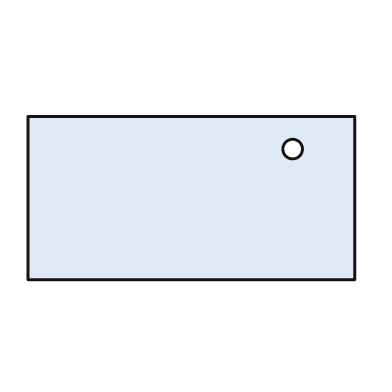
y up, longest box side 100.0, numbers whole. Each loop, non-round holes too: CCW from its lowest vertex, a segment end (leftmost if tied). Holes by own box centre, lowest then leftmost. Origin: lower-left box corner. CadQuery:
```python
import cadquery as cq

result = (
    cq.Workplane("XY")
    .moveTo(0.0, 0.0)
    .lineTo(100.0, 0.0)
    .lineTo(100.0, 50.0)
    .lineTo(0.0, 50.0)
    .close()
    .moveTo(81.0, 40.0)
    .circle(3.0)
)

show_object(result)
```